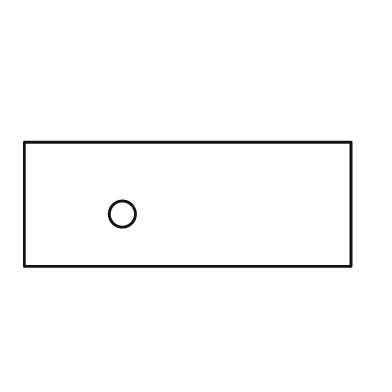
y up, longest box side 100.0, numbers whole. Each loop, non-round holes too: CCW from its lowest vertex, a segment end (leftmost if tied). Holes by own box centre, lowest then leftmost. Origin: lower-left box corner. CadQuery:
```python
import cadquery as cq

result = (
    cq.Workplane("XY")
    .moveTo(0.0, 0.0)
    .lineTo(100.0, 0.0)
    .lineTo(100.0, 38.0)
    .lineTo(0.0, 38.0)
    .close()
    .moveTo(30.0, 16.0)
    .circle(4.0)
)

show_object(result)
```